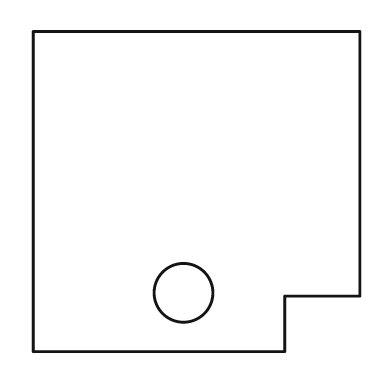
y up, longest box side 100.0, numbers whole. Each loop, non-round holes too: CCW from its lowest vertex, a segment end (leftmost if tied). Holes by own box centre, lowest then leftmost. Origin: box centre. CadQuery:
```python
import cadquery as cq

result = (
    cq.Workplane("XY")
    .moveTo(-50.0, -49.0)
    .lineTo(27.0, -49.0)
    .lineTo(27.0, -32.0)
    .lineTo(50.0, -32.0)
    .lineTo(50.0, 49.0)
    .lineTo(-50.0, 49.0)
    .close()
    .moveTo(-4.0, -31.0)
    .circle(9.0)
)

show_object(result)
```